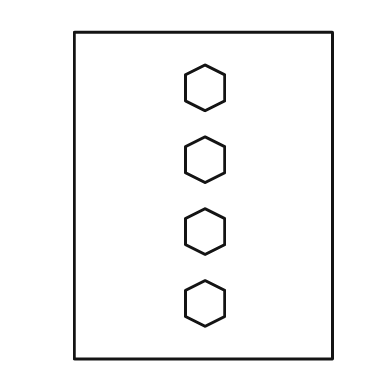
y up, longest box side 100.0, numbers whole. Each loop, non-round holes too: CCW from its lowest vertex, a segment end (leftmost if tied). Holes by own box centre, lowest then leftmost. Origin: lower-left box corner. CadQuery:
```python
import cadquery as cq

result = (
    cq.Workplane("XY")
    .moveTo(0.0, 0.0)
    .lineTo(79.0, 0.0)
    .lineTo(79.0, 100.0)
    .lineTo(0.0, 100.0)
    .close()
    .moveTo(40.0, 10.0)
    .lineTo(46.0, 13.0)
    .lineTo(46.0, 21.0)
    .lineTo(40.0, 24.0)
    .lineTo(34.0, 21.0)
    .lineTo(34.0, 13.0)
    .close()
    .moveTo(40.0, 32.0)
    .lineTo(46.0, 35.0)
    .lineTo(46.0, 43.0)
    .lineTo(40.0, 46.0)
    .lineTo(34.0, 43.0)
    .lineTo(34.0, 35.0)
    .close()
    .moveTo(40.0, 54.0)
    .lineTo(46.0, 57.0)
    .lineTo(46.0, 65.0)
    .lineTo(40.0, 68.0)
    .lineTo(34.0, 65.0)
    .lineTo(34.0, 57.0)
    .close()
    .moveTo(40.0, 76.0)
    .lineTo(46.0, 79.0)
    .lineTo(46.0, 87.0)
    .lineTo(40.0, 90.0)
    .lineTo(34.0, 87.0)
    .lineTo(34.0, 79.0)
    .close()
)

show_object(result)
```